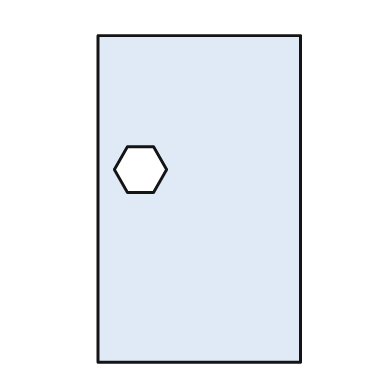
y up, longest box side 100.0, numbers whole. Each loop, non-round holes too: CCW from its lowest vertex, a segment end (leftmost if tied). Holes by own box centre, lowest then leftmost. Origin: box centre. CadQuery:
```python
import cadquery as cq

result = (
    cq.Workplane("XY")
    .moveTo(-31.0, -50.0)
    .lineTo(31.0, -50.0)
    .lineTo(31.0, 50.0)
    .lineTo(-31.0, 50.0)
    .close()
    .moveTo(-22.0, 2.0)
    .lineTo(-14.0, 2.0)
    .lineTo(-10.0, 9.0)
    .lineTo(-14.0, 16.0)
    .lineTo(-22.0, 16.0)
    .lineTo(-26.0, 9.0)
    .close()
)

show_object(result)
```